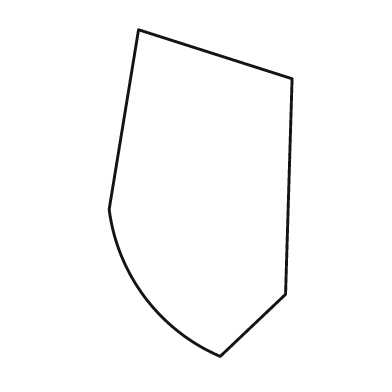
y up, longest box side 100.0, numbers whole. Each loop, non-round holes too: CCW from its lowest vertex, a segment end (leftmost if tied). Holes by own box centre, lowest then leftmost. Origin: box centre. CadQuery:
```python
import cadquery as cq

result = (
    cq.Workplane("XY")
    .moveTo(6.0, -50.0)
    .lineTo(26.0, -31.0)
    .lineTo(28.0, 35.0)
    .lineTo(-19.0, 50.0)
    .lineTo(-28.0, -5.0)
    .threePointArc((-17.0, -32.0), (6.0, -50.0))
    .close()
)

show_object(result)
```